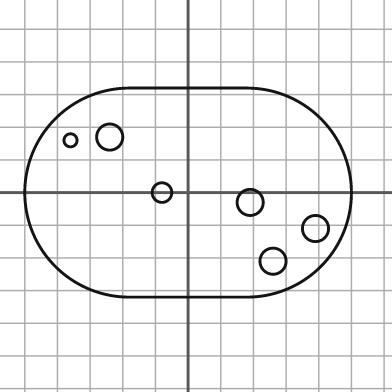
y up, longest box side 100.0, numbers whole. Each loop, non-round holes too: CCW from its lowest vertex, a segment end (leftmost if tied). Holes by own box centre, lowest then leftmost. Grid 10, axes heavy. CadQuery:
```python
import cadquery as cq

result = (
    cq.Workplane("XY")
    .moveTo(-18.0, -32.0)
    .lineTo(18.0, -32.0)
    .threePointArc((50.0, 0.0), (18.0, 32.0))
    .lineTo(-18.0, 32.0)
    .threePointArc((-50.0, 0.0), (-18.0, -32.0))
    .close()
    .moveTo(26.0, -21.0)
    .circle(4.0)
    .moveTo(39.0, -11.0)
    .circle(4.0)
    .moveTo(19.0, -3.0)
    .circle(4.0)
    .moveTo(-8.0, 0.0)
    .circle(3.0)
    .moveTo(-36.0, 16.0)
    .circle(2.0)
    .moveTo(-24.0, 17.0)
    .circle(4.0)
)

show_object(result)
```